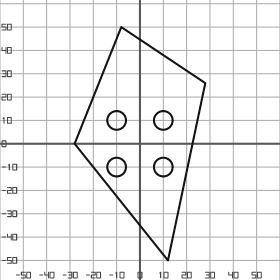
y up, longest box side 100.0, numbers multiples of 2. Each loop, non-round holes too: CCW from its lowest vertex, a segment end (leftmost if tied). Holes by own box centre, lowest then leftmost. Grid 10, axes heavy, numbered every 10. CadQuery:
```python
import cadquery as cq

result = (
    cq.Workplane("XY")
    .moveTo(12.0, -50.0)
    .lineTo(28.0, 26.0)
    .lineTo(-8.0, 50.0)
    .lineTo(-28.0, 0.0)
    .close()
    .moveTo(-10.0, -10.0)
    .circle(4.0)
    .moveTo(10.0, -10.0)
    .circle(4.0)
    .moveTo(-10.0, 10.0)
    .circle(4.0)
    .moveTo(10.0, 10.0)
    .circle(4.0)
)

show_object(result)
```